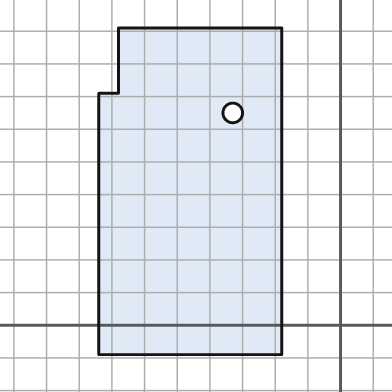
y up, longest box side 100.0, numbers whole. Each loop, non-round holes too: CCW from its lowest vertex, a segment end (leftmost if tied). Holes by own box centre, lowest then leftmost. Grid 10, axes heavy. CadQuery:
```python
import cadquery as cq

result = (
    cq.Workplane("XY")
    .moveTo(-74.0, -9.0)
    .lineTo(-18.0, -9.0)
    .lineTo(-18.0, 91.0)
    .lineTo(-68.0, 91.0)
    .lineTo(-68.0, 71.0)
    .lineTo(-74.0, 71.0)
    .close()
    .moveTo(-33.0, 65.0)
    .circle(3.0)
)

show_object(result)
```